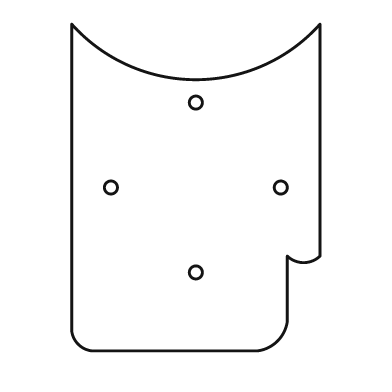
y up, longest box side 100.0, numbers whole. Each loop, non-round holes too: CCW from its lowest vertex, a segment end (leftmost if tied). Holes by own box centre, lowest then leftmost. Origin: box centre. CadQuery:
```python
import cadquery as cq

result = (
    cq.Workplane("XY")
    .moveTo(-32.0, -50.0)
    .lineTo(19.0, -50.0)
    .threePointArc((25.0, -47.0), (28.0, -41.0))
    .lineTo(28.0, -21.0)
    .threePointArc((33.0, -23.0), (38.0, -21.0))
    .lineTo(38.0, 50.0)
    .threePointArc((0.0, 33.0), (-38.0, 50.0))
    .lineTo(-38.0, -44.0)
    .threePointArc((-36.0, -48.0), (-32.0, -50.0))
    .close()
    .moveTo(0.0, -26.0)
    .circle(2.0)
    .moveTo(-26.0, 0.0)
    .circle(2.0)
    .moveTo(26.0, 0.0)
    .circle(2.0)
    .moveTo(0.0, 26.0)
    .circle(2.0)
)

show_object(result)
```